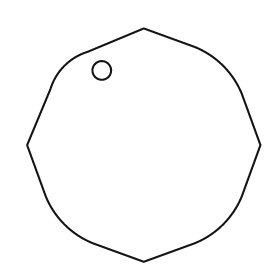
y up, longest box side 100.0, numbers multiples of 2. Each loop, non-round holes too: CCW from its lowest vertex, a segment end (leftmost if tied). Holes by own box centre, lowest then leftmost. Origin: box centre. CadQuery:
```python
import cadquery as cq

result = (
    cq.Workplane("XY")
    .moveTo(0.0, -50.0)
    .lineTo(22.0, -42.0)
    .threePointArc((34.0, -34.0), (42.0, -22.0))
    .lineTo(50.0, 0.0)
    .lineTo(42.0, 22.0)
    .threePointArc((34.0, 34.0), (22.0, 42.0))
    .lineTo(0.0, 50.0)
    .lineTo(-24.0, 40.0)
    .threePointArc((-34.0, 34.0), (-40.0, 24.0))
    .lineTo(-50.0, 0.0)
    .lineTo(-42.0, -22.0)
    .threePointArc((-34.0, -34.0), (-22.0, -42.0))
    .close()
    .moveTo(-18.0, 32.0)
    .circle(4.0)
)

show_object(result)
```